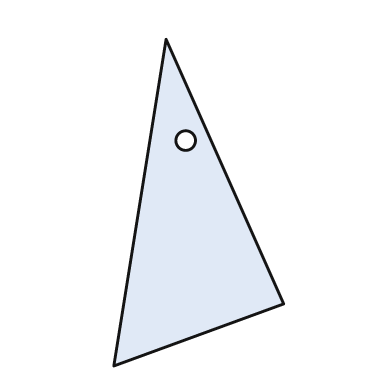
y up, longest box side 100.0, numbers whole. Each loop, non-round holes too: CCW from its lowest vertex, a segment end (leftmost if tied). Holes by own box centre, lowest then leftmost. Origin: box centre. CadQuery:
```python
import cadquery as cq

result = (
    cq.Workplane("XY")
    .moveTo(-26.0, -50.0)
    .lineTo(26.0, -31.0)
    .lineTo(-10.0, 50.0)
    .close()
    .moveTo(-4.0, 19.0)
    .circle(3.0)
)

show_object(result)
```